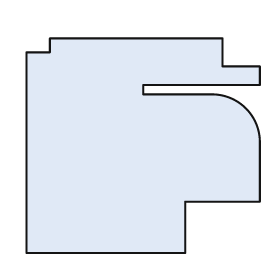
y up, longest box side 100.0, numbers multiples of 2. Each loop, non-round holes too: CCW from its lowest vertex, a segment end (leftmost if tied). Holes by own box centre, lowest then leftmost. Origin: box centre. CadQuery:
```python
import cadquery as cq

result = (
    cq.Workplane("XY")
    .moveTo(-50.0, -46.0)
    .lineTo(18.0, -46.0)
    .lineTo(18.0, -24.0)
    .lineTo(50.0, -24.0)
    .lineTo(50.0, 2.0)
    .threePointArc((44.0, 16.0), (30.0, 22.0))
    .lineTo(0.0, 22.0)
    .lineTo(0.0, 26.0)
    .lineTo(50.0, 26.0)
    .lineTo(50.0, 34.0)
    .lineTo(34.0, 34.0)
    .lineTo(34.0, 46.0)
    .lineTo(-40.0, 46.0)
    .lineTo(-40.0, 40.0)
    .lineTo(-50.0, 40.0)
    .close()
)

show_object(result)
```